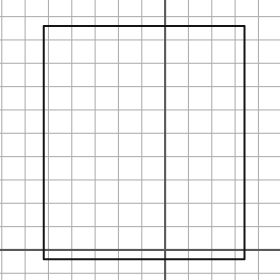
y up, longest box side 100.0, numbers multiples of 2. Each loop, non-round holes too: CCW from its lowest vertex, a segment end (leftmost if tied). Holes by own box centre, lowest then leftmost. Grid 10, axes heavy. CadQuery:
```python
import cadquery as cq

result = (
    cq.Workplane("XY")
    .moveTo(-52.0, -4.0)
    .lineTo(34.0, -4.0)
    .lineTo(34.0, 96.0)
    .lineTo(-52.0, 96.0)
    .close()
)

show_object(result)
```